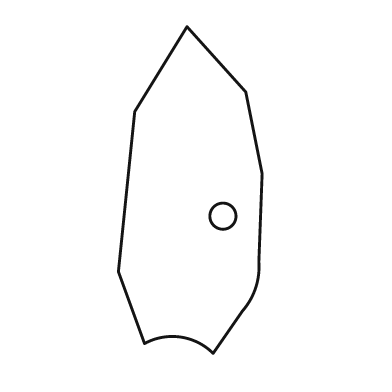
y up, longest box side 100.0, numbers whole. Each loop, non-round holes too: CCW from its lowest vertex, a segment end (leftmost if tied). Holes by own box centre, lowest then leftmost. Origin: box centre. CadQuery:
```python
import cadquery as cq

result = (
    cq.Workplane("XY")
    .moveTo(7.0, -50.0)
    .lineTo(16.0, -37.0)
    .threePointArc((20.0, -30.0), (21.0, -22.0))
    .lineTo(22.0, 5.0)
    .lineTo(17.0, 30.0)
    .lineTo(-1.0, 50.0)
    .lineTo(-17.0, 24.0)
    .lineTo(-22.0, -25.0)
    .lineTo(-14.0, -47.0)
    .threePointArc((-3.0, -45.0), (7.0, -50.0))
    .close()
    .moveTo(10.0, -8.0)
    .circle(4.0)
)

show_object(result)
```